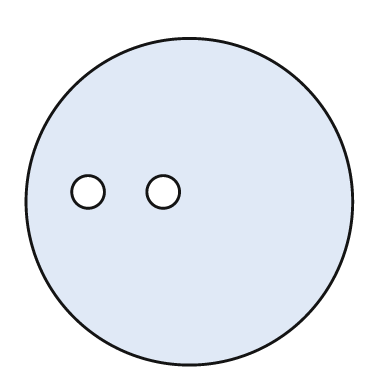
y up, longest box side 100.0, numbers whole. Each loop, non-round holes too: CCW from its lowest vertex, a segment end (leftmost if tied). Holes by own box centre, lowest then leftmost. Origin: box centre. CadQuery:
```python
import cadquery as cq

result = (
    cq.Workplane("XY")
    .moveTo(0.0, 0.0)
    .circle(50.0)
    .moveTo(-31.0, 3.0)
    .circle(5.0)
    .moveTo(-8.0, 3.0)
    .circle(5.0)
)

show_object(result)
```